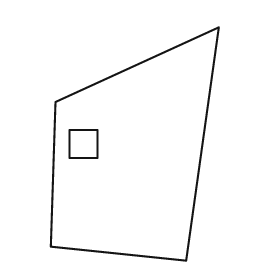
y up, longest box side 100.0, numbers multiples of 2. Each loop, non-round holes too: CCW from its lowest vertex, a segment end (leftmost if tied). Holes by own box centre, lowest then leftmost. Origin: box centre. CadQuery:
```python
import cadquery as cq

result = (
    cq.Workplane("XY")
    .moveTo(22.0, -50.0)
    .lineTo(36.0, 50.0)
    .lineTo(-34.0, 18.0)
    .lineTo(-36.0, -44.0)
    .close()
    .moveTo(-28.0, -6.0)
    .lineTo(-16.0, -6.0)
    .lineTo(-16.0, 6.0)
    .lineTo(-28.0, 6.0)
    .close()
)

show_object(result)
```